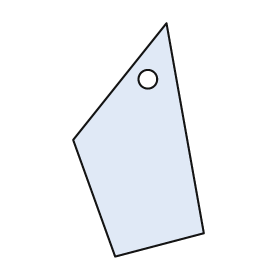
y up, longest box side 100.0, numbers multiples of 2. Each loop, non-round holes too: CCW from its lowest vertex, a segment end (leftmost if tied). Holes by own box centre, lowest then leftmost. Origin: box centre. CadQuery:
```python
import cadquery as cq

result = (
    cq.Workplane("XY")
    .moveTo(-10.0, -50.0)
    .lineTo(28.0, -40.0)
    .lineTo(12.0, 50.0)
    .lineTo(-28.0, 0.0)
    .close()
    .moveTo(4.0, 26.0)
    .circle(4.0)
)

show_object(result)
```